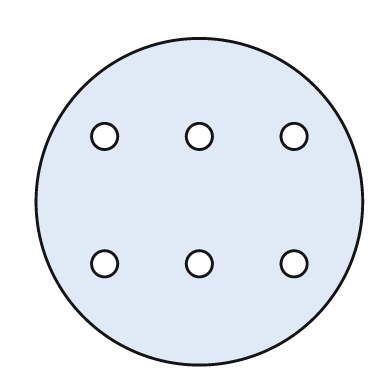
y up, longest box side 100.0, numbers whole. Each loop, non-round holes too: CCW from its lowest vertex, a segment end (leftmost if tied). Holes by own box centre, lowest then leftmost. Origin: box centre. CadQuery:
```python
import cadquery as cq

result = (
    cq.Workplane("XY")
    .moveTo(0.0, 0.0)
    .circle(50.0)
    .moveTo(-29.0, -19.0)
    .circle(4.0)
    .moveTo(0.0, -19.0)
    .circle(4.0)
    .moveTo(29.0, -19.0)
    .circle(4.0)
    .moveTo(-29.0, 20.0)
    .circle(4.0)
    .moveTo(0.0, 20.0)
    .circle(4.0)
    .moveTo(29.0, 20.0)
    .circle(4.0)
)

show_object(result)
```